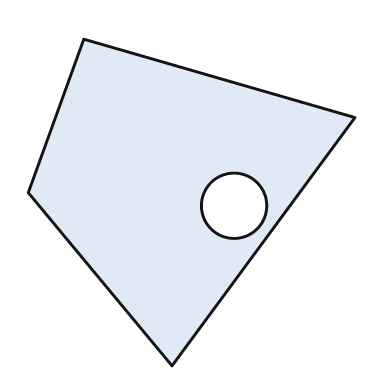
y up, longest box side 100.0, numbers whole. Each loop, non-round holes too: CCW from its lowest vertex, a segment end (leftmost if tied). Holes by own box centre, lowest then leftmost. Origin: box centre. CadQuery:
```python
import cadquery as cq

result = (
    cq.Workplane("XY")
    .moveTo(-6.0, -50.0)
    .lineTo(50.0, 26.0)
    .lineTo(-33.0, 50.0)
    .lineTo(-50.0, 3.0)
    .close()
    .moveTo(13.0, -1.0)
    .circle(10.0)
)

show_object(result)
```